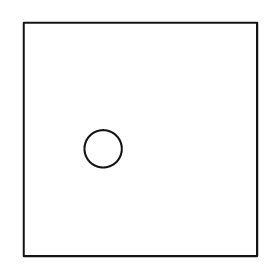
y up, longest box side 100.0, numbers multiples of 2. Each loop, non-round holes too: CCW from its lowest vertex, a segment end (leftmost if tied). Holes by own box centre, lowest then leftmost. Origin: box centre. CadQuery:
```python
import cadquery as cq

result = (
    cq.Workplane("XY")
    .moveTo(-50.0, -50.0)
    .lineTo(50.0, -50.0)
    .lineTo(50.0, 50.0)
    .lineTo(-50.0, 50.0)
    .close()
    .moveTo(-16.0, -4.0)
    .circle(8.0)
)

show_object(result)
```